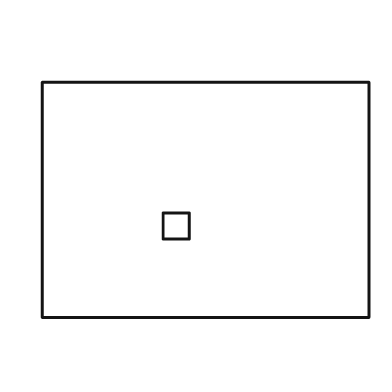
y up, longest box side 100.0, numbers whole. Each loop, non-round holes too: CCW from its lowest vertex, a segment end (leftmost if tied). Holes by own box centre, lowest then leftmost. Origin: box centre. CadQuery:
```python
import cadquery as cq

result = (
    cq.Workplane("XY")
    .moveTo(-50.0, -36.0)
    .lineTo(50.0, -36.0)
    .lineTo(50.0, 36.0)
    .lineTo(-50.0, 36.0)
    .close()
    .moveTo(-13.0, -12.0)
    .lineTo(-5.0, -12.0)
    .lineTo(-5.0, -4.0)
    .lineTo(-13.0, -4.0)
    .close()
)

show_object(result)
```